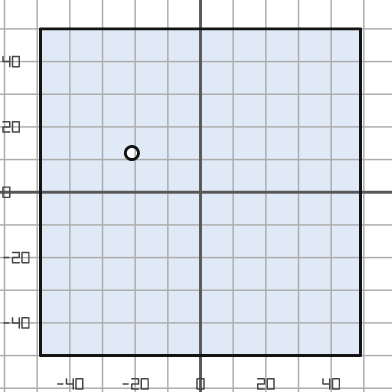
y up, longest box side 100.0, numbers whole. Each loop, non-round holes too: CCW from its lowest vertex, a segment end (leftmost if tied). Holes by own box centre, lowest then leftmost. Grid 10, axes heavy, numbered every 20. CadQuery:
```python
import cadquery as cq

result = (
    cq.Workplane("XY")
    .moveTo(-49.0, -50.0)
    .lineTo(49.0, -50.0)
    .lineTo(49.0, 50.0)
    .lineTo(-49.0, 50.0)
    .close()
    .moveTo(-21.0, 12.0)
    .circle(2.0)
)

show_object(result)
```